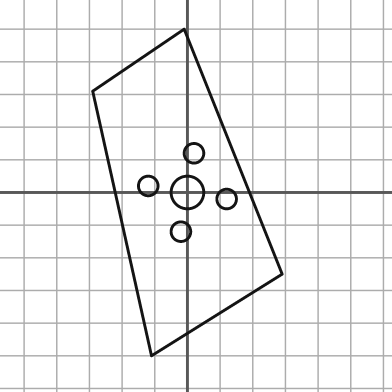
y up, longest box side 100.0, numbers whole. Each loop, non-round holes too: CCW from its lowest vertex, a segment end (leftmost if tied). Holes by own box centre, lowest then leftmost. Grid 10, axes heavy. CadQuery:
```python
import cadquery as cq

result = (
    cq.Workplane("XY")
    .moveTo(-11.0, -50.0)
    .lineTo(29.0, -25.0)
    .lineTo(-1.0, 50.0)
    .lineTo(-29.0, 31.0)
    .close()
    .moveTo(-2.0, -12.0)
    .circle(3.0)
    .moveTo(12.0, -2.0)
    .circle(3.0)
    .moveTo(0.0, 0.0)
    .circle(5.0)
    .moveTo(-12.0, 2.0)
    .circle(3.0)
    .moveTo(2.0, 12.0)
    .circle(3.0)
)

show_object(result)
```